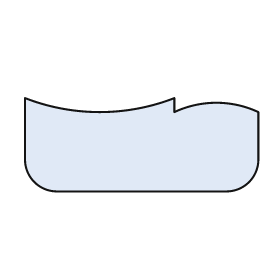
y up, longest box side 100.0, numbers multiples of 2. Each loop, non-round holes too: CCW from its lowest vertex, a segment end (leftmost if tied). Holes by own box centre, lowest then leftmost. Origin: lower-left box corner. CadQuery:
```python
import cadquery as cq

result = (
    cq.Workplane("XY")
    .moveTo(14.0, 0.0)
    .lineTo(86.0, 0.0)
    .threePointArc((96.0, 4.0), (100.0, 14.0))
    .lineTo(100.0, 34.0)
    .threePointArc((82.0, 38.0), (64.0, 34.0))
    .lineTo(64.0, 40.0)
    .threePointArc((32.0, 34.0), (0.0, 40.0))
    .lineTo(0.0, 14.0)
    .threePointArc((4.0, 4.0), (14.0, 0.0))
    .close()
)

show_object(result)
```